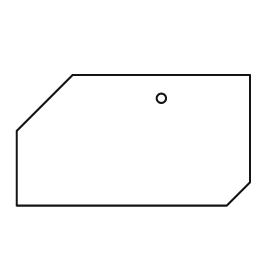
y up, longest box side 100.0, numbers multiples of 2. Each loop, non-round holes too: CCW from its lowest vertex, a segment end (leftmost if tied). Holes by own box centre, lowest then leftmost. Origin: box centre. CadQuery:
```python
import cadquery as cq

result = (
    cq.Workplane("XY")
    .moveTo(-50.0, -28.0)
    .lineTo(40.0, -28.0)
    .lineTo(50.0, -18.0)
    .lineTo(50.0, 28.0)
    .lineTo(-26.0, 28.0)
    .lineTo(-50.0, 4.0)
    .close()
    .moveTo(12.0, 18.0)
    .circle(2.0)
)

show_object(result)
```